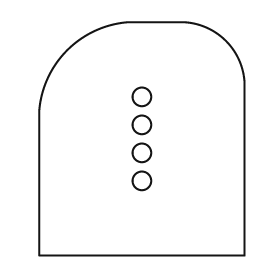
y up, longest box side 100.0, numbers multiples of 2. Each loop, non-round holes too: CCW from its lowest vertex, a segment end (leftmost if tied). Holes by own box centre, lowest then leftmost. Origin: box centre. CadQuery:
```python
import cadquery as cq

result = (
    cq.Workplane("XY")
    .moveTo(-44.0, -50.0)
    .lineTo(44.0, -50.0)
    .lineTo(44.0, 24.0)
    .threePointArc((36.0, 42.0), (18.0, 50.0))
    .lineTo(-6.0, 50.0)
    .threePointArc((-32.0, 38.0), (-44.0, 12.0))
    .close()
    .moveTo(0.0, -18.0)
    .circle(4.0)
    .moveTo(0.0, -6.0)
    .circle(4.0)
    .moveTo(0.0, 6.0)
    .circle(4.0)
    .moveTo(0.0, 18.0)
    .circle(4.0)
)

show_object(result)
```